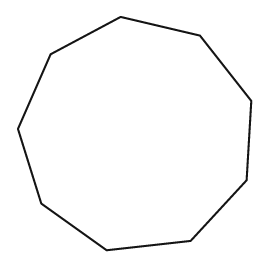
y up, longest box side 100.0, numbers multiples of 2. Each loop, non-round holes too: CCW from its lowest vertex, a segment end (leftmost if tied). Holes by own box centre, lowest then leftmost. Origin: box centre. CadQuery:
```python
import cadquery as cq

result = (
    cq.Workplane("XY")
    .moveTo(-12.0, -50.0)
    .lineTo(24.0, -46.0)
    .lineTo(48.0, -20.0)
    .lineTo(50.0, 14.0)
    .lineTo(28.0, 42.0)
    .lineTo(-6.0, 50.0)
    .lineTo(-36.0, 34.0)
    .lineTo(-50.0, 2.0)
    .lineTo(-40.0, -30.0)
    .close()
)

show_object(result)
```